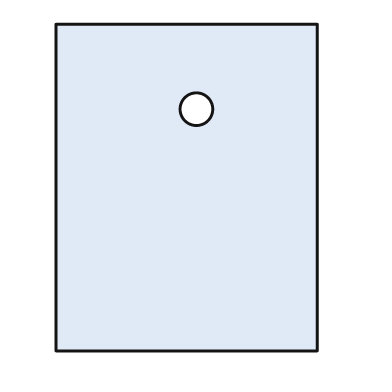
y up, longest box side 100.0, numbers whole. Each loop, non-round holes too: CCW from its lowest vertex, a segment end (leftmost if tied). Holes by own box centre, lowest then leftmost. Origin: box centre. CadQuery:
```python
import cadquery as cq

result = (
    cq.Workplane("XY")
    .moveTo(-40.0, -50.0)
    .lineTo(40.0, -50.0)
    .lineTo(40.0, 50.0)
    .lineTo(-40.0, 50.0)
    .close()
    .moveTo(3.0, 24.0)
    .circle(5.0)
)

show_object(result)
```